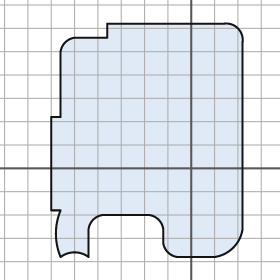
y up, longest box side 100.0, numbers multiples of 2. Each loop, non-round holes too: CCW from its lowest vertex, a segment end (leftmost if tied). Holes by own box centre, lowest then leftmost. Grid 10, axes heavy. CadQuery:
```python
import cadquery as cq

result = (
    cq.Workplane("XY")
    .moveTo(-56.0, -38.0)
    .threePointArc((-50.0, -36.0), (-44.0, -38.0))
    .lineTo(-44.0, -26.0)
    .threePointArc((-42.0, -22.0), (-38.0, -20.0))
    .lineTo(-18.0, -20.0)
    .threePointArc((-14.0, -22.0), (-12.0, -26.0))
    .lineTo(-12.0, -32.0)
    .threePointArc((-10.0, -36.0), (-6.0, -38.0))
    .lineTo(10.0, -38.0)
    .threePointArc((18.0, -34.0), (22.0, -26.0))
    .lineTo(22.0, 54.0)
    .threePointArc((20.0, 60.0), (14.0, 62.0))
    .lineTo(-36.0, 62.0)
    .lineTo(-36.0, 56.0)
    .lineTo(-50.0, 56.0)
    .threePointArc((-54.0, 54.0), (-56.0, 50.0))
    .lineTo(-56.0, 22.0)
    .lineTo(-60.0, 22.0)
    .lineTo(-60.0, -18.0)
    .lineTo(-56.0, -18.0)
    .threePointArc((-58.0, -28.0), (-56.0, -38.0))
    .close()
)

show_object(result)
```